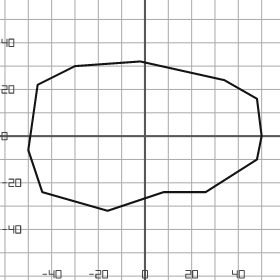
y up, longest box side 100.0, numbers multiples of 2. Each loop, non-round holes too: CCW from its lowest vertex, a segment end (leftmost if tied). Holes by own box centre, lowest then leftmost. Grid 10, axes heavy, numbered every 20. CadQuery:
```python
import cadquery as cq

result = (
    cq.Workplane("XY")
    .moveTo(-16.0, -32.0)
    .lineTo(8.0, -24.0)
    .lineTo(26.0, -24.0)
    .lineTo(48.0, -10.0)
    .lineTo(50.0, 0.0)
    .lineTo(48.0, 16.0)
    .lineTo(34.0, 24.0)
    .lineTo(-2.0, 32.0)
    .lineTo(-30.0, 30.0)
    .lineTo(-46.0, 22.0)
    .lineTo(-50.0, -6.0)
    .lineTo(-44.0, -24.0)
    .close()
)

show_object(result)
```